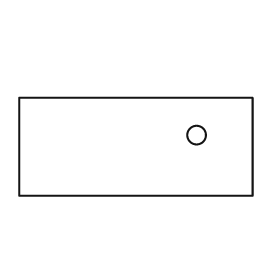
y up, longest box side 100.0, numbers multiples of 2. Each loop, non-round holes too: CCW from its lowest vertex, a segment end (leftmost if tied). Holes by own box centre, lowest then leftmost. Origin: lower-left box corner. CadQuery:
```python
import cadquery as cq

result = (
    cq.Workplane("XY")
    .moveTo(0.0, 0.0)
    .lineTo(100.0, 0.0)
    .lineTo(100.0, 42.0)
    .lineTo(0.0, 42.0)
    .close()
    .moveTo(76.0, 26.0)
    .circle(4.0)
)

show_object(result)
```